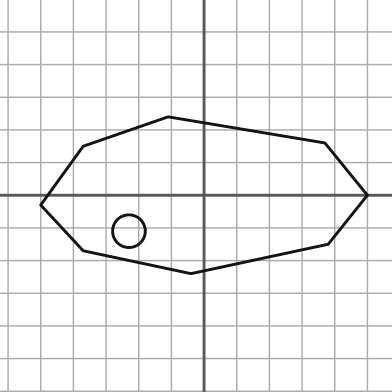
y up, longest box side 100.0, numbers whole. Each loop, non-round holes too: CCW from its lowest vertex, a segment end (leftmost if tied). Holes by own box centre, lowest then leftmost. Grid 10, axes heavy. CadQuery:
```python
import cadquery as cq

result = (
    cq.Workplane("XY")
    .moveTo(-4.0, -24.0)
    .lineTo(38.0, -15.0)
    .lineTo(50.0, 0.0)
    .lineTo(37.0, 16.0)
    .lineTo(-11.0, 24.0)
    .lineTo(-37.0, 15.0)
    .lineTo(-50.0, -3.0)
    .lineTo(-37.0, -17.0)
    .close()
    .moveTo(-23.0, -11.0)
    .circle(5.0)
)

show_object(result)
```